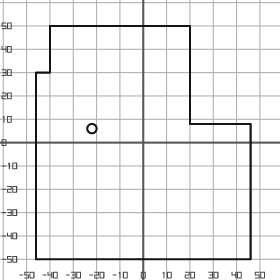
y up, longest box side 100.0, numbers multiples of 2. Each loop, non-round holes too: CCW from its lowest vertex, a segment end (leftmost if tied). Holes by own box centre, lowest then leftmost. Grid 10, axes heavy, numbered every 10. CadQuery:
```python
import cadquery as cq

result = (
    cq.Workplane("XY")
    .moveTo(-46.0, -50.0)
    .lineTo(46.0, -50.0)
    .lineTo(46.0, 8.0)
    .lineTo(20.0, 8.0)
    .lineTo(20.0, 50.0)
    .lineTo(-40.0, 50.0)
    .lineTo(-40.0, 30.0)
    .lineTo(-46.0, 30.0)
    .close()
    .moveTo(-22.0, 6.0)
    .circle(2.0)
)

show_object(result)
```